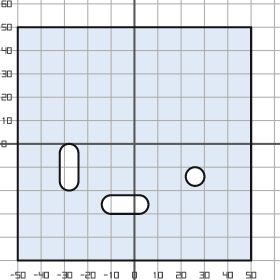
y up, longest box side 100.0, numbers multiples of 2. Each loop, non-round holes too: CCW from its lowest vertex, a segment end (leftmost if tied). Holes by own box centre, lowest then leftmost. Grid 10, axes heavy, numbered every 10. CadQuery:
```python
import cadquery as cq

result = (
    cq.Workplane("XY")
    .moveTo(-50.0, -50.0)
    .lineTo(50.0, -50.0)
    .lineTo(50.0, 50.0)
    .lineTo(-50.0, 50.0)
    .close()
    .moveTo(-10.0, -30.0)
    .lineTo(2.0, -30.0)
    .threePointArc((6.0, -26.0), (2.0, -22.0))
    .lineTo(-10.0, -22.0)
    .threePointArc((-14.0, -26.0), (-10.0, -30.0))
    .close()
    .moveTo(26.0, -14.0)
    .circle(4.0)
    .moveTo(-32.0, -16.0)
    .threePointArc((-28.0, -20.0), (-24.0, -16.0))
    .lineTo(-24.0, -4.0)
    .threePointArc((-28.0, 0.0), (-32.0, -4.0))
    .close()
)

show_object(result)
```